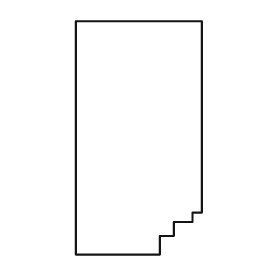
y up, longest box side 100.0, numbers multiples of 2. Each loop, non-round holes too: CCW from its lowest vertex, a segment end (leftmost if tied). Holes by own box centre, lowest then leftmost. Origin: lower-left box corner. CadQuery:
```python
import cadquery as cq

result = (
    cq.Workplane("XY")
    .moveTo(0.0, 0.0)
    .lineTo(36.0, 0.0)
    .lineTo(36.0, 8.0)
    .lineTo(42.0, 8.0)
    .lineTo(42.0, 14.0)
    .lineTo(50.0, 14.0)
    .lineTo(50.0, 18.0)
    .lineTo(54.0, 18.0)
    .lineTo(54.0, 100.0)
    .lineTo(0.0, 100.0)
    .close()
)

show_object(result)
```